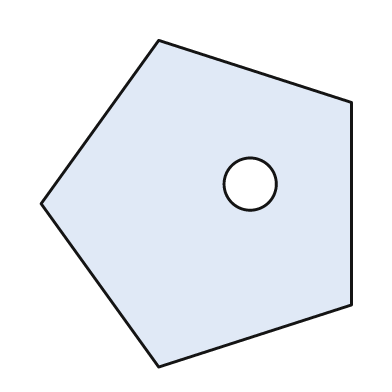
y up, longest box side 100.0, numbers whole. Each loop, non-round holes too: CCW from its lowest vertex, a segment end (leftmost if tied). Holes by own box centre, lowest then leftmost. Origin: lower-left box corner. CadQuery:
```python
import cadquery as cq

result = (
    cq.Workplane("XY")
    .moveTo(36.0, 0.0)
    .lineTo(95.0, 19.0)
    .lineTo(95.0, 81.0)
    .lineTo(36.0, 100.0)
    .lineTo(0.0, 50.0)
    .close()
    .moveTo(64.0, 56.0)
    .circle(8.0)
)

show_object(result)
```